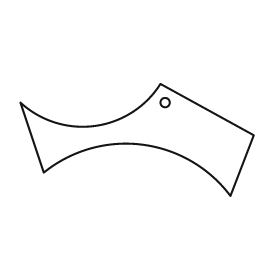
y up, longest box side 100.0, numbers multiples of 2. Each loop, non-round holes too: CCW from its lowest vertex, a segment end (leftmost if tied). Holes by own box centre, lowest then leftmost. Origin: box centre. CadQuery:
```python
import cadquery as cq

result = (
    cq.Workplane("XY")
    .moveTo(40.0, -24.0)
    .lineTo(50.0, 2.0)
    .lineTo(10.0, 24.0)
    .threePointArc((-18.0, 6.0), (-50.0, 16.0))
    .lineTo(-40.0, -14.0)
    .threePointArc((2.0, -2.0), (40.0, -24.0))
    .close()
    .moveTo(12.0, 16.0)
    .circle(2.0)
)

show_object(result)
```